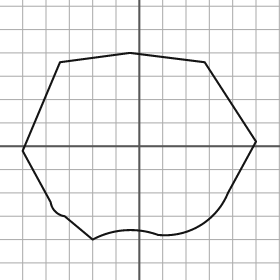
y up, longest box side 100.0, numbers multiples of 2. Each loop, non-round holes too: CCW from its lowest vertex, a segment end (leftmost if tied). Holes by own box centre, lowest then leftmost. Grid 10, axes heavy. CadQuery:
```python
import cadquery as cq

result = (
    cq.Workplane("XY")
    .moveTo(-20.0, -40.0)
    .threePointArc((-6.0, -36.0), (8.0, -38.0))
    .threePointArc((26.0, -34.0), (38.0, -20.0))
    .lineTo(50.0, 2.0)
    .lineTo(28.0, 36.0)
    .lineTo(-4.0, 40.0)
    .lineTo(-34.0, 36.0)
    .lineTo(-50.0, -2.0)
    .lineTo(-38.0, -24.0)
    .threePointArc((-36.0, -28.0), (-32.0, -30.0))
    .close()
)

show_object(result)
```